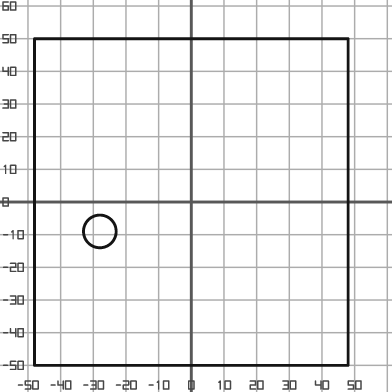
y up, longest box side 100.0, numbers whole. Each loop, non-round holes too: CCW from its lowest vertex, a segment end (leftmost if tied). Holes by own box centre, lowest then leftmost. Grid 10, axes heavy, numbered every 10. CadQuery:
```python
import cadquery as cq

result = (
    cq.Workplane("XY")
    .moveTo(-48.0, -50.0)
    .lineTo(48.0, -50.0)
    .lineTo(48.0, 50.0)
    .lineTo(-48.0, 50.0)
    .close()
    .moveTo(-28.0, -9.0)
    .circle(5.0)
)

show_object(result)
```